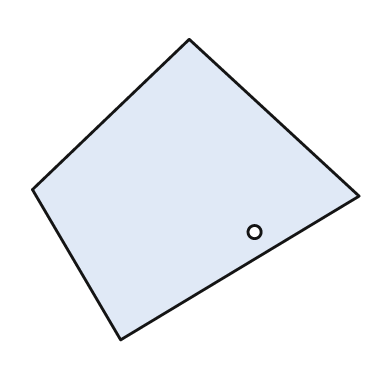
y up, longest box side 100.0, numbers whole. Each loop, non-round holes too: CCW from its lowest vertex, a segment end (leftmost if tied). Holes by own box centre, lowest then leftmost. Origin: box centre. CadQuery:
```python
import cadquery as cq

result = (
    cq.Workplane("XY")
    .moveTo(-23.0, -46.0)
    .lineTo(50.0, -2.0)
    .lineTo(-2.0, 46.0)
    .lineTo(-50.0, 0.0)
    .close()
    .moveTo(18.0, -13.0)
    .circle(2.0)
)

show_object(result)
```